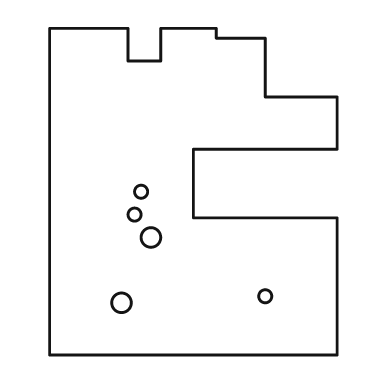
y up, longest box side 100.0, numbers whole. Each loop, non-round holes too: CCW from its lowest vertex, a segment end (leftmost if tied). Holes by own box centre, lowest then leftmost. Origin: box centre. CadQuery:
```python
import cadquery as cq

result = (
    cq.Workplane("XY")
    .moveTo(-44.0, -50.0)
    .lineTo(44.0, -50.0)
    .lineTo(44.0, -8.0)
    .lineTo(0.0, -8.0)
    .lineTo(0.0, 13.0)
    .lineTo(44.0, 13.0)
    .lineTo(44.0, 29.0)
    .lineTo(22.0, 29.0)
    .lineTo(22.0, 47.0)
    .lineTo(7.0, 47.0)
    .lineTo(7.0, 50.0)
    .lineTo(-10.0, 50.0)
    .lineTo(-10.0, 40.0)
    .lineTo(-20.0, 40.0)
    .lineTo(-20.0, 50.0)
    .lineTo(-44.0, 50.0)
    .close()
    .moveTo(-22.0, -34.0)
    .circle(3.0)
    .moveTo(22.0, -32.0)
    .circle(2.0)
    .moveTo(-13.0, -14.0)
    .circle(3.0)
    .moveTo(-18.0, -7.0)
    .circle(2.0)
    .moveTo(-16.0, 0.0)
    .circle(2.0)
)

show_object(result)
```